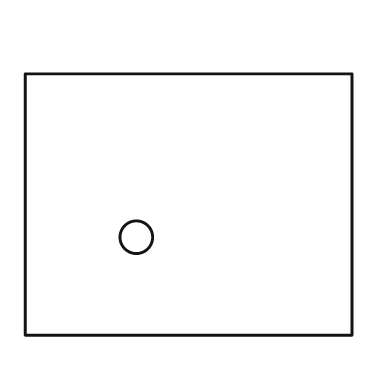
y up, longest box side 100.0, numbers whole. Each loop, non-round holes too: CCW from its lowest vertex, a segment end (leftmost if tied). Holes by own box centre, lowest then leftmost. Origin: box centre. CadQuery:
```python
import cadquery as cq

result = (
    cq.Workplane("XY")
    .moveTo(-50.0, -40.0)
    .lineTo(50.0, -40.0)
    .lineTo(50.0, 40.0)
    .lineTo(-50.0, 40.0)
    .close()
    .moveTo(-16.0, -10.0)
    .circle(5.0)
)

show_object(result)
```